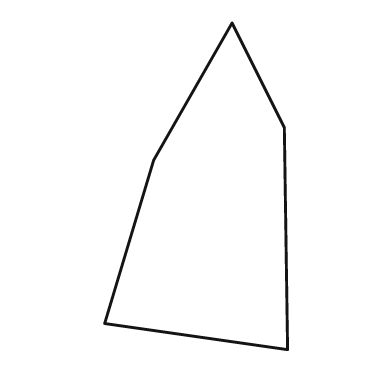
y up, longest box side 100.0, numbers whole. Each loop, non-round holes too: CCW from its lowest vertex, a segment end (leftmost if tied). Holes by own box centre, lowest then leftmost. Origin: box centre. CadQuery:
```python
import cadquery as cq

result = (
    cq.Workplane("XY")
    .moveTo(28.0, -50.0)
    .lineTo(27.0, 18.0)
    .lineTo(11.0, 50.0)
    .lineTo(-13.0, 8.0)
    .lineTo(-28.0, -42.0)
    .close()
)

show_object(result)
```